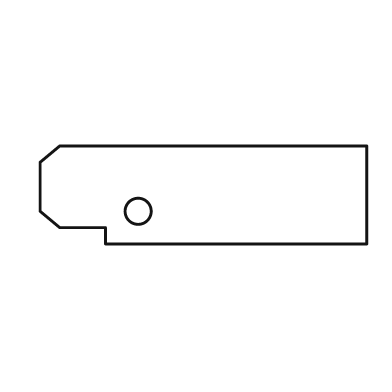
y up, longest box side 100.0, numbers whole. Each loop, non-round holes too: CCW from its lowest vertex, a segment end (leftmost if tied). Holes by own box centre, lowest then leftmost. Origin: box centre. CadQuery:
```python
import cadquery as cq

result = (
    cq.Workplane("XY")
    .moveTo(-30.0, -15.0)
    .lineTo(50.0, -15.0)
    .lineTo(50.0, 15.0)
    .lineTo(-44.0, 15.0)
    .lineTo(-50.0, 10.0)
    .lineTo(-50.0, -5.0)
    .lineTo(-44.0, -10.0)
    .lineTo(-30.0, -10.0)
    .close()
    .moveTo(-20.0, -5.0)
    .circle(4.0)
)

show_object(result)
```